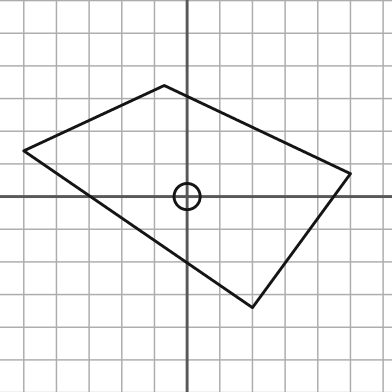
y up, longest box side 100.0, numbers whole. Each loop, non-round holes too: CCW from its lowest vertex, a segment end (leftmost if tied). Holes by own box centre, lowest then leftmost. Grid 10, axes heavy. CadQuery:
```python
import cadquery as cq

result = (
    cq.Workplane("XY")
    .moveTo(20.0, -34.0)
    .lineTo(50.0, 7.0)
    .lineTo(-7.0, 34.0)
    .lineTo(-50.0, 14.0)
    .close()
    .moveTo(0.0, 0.0)
    .circle(4.0)
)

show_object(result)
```